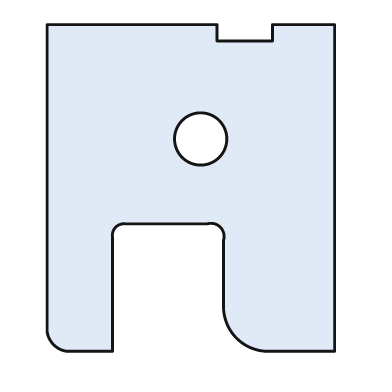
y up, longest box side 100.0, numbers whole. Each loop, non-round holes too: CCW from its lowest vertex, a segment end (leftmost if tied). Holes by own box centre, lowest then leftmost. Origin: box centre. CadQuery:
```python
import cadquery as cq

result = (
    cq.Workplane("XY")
    .moveTo(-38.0, -50.0)
    .lineTo(-24.0, -50.0)
    .lineTo(-24.0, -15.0)
    .threePointArc((-23.0, -12.0), (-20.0, -11.0))
    .lineTo(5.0, -11.0)
    .threePointArc((9.0, -12.0), (10.0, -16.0))
    .lineTo(10.0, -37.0)
    .threePointArc((14.0, -46.0), (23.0, -50.0))
    .lineTo(44.0, -50.0)
    .lineTo(44.0, 50.0)
    .lineTo(25.0, 50.0)
    .lineTo(25.0, 45.0)
    .lineTo(8.0, 45.0)
    .lineTo(8.0, 50.0)
    .lineTo(-44.0, 50.0)
    .lineTo(-44.0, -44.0)
    .threePointArc((-42.0, -48.0), (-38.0, -50.0))
    .close()
    .moveTo(3.0, 15.0)
    .circle(8.0)
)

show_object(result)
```